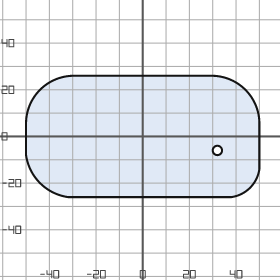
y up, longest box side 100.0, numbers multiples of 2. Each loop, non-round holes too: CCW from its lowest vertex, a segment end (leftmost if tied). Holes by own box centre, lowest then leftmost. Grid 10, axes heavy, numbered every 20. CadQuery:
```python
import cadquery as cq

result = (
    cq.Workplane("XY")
    .moveTo(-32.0, -26.0)
    .lineTo(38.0, -26.0)
    .threePointArc((46.0, -22.0), (50.0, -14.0))
    .lineTo(50.0, 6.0)
    .threePointArc((44.0, 20.0), (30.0, 26.0))
    .lineTo(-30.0, 26.0)
    .threePointArc((-44.0, 20.0), (-50.0, 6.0))
    .lineTo(-50.0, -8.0)
    .threePointArc((-44.0, -20.0), (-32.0, -26.0))
    .close()
    .moveTo(32.0, -6.0)
    .circle(2.0)
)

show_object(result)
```